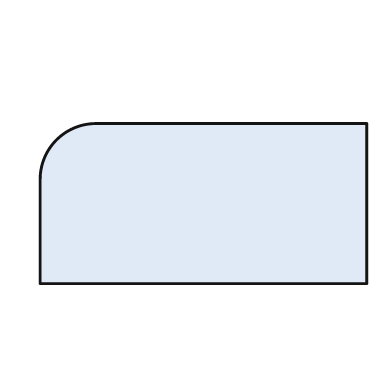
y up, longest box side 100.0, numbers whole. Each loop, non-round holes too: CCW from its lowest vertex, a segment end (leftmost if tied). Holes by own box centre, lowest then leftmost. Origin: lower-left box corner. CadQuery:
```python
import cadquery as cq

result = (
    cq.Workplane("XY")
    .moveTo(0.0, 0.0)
    .lineTo(100.0, 0.0)
    .lineTo(100.0, 49.0)
    .lineTo(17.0, 49.0)
    .threePointArc((5.0, 44.0), (0.0, 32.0))
    .close()
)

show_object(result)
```